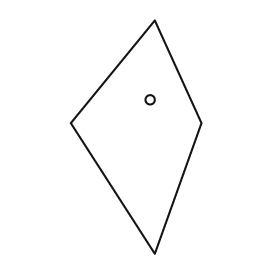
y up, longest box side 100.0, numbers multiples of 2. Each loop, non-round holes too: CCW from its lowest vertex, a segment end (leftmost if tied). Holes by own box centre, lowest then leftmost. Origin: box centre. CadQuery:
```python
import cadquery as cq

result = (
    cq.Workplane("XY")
    .moveTo(8.0, -50.0)
    .lineTo(28.0, 6.0)
    .lineTo(8.0, 50.0)
    .lineTo(-28.0, 6.0)
    .close()
    .moveTo(6.0, 16.0)
    .circle(2.0)
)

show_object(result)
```